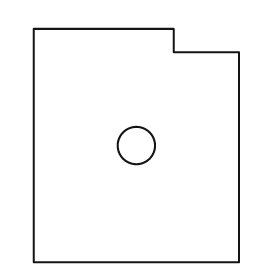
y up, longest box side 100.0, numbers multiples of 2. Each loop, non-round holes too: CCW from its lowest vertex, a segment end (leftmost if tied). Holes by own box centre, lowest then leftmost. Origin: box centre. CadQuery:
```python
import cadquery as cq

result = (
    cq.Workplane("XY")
    .moveTo(-44.0, -50.0)
    .lineTo(44.0, -50.0)
    .lineTo(44.0, 40.0)
    .lineTo(16.0, 40.0)
    .lineTo(16.0, 50.0)
    .lineTo(-44.0, 50.0)
    .close()
    .moveTo(0.0, 0.0)
    .circle(8.0)
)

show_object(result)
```